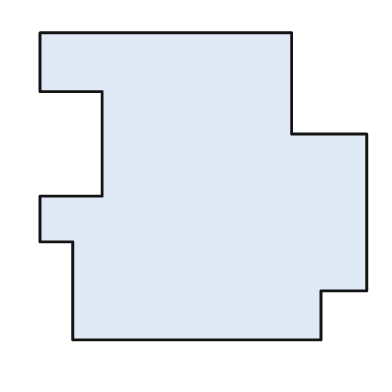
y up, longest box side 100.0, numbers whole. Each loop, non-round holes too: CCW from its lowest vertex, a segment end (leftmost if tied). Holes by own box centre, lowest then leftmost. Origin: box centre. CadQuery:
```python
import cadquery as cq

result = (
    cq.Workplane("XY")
    .moveTo(-40.0, -47.0)
    .lineTo(36.0, -47.0)
    .lineTo(36.0, -32.0)
    .lineTo(50.0, -32.0)
    .lineTo(50.0, 16.0)
    .lineTo(27.0, 16.0)
    .lineTo(27.0, 47.0)
    .lineTo(-50.0, 47.0)
    .lineTo(-50.0, 29.0)
    .lineTo(-31.0, 29.0)
    .lineTo(-31.0, -3.0)
    .lineTo(-50.0, -3.0)
    .lineTo(-50.0, -17.0)
    .lineTo(-40.0, -17.0)
    .close()
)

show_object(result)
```